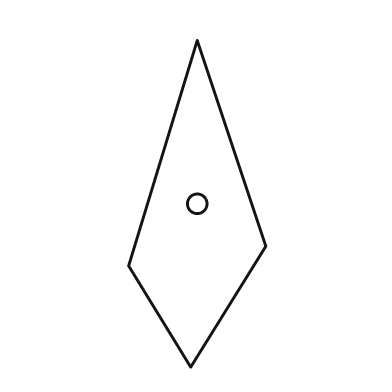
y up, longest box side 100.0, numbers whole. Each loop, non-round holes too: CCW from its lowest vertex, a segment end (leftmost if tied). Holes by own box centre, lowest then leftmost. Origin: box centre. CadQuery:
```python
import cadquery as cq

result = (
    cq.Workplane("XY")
    .moveTo(-2.0, -50.0)
    .lineTo(21.0, -13.0)
    .lineTo(0.0, 50.0)
    .lineTo(-21.0, -19.0)
    .close()
    .moveTo(0.0, 0.0)
    .circle(3.0)
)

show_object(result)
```